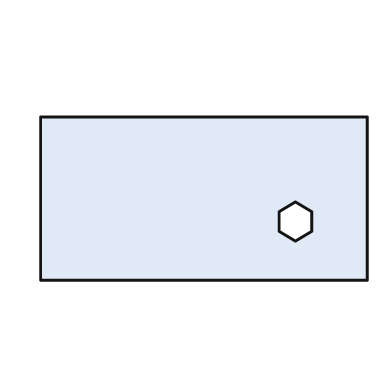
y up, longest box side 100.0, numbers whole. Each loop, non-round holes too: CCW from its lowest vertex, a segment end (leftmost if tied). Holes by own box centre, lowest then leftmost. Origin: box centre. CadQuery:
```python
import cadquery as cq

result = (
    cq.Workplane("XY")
    .moveTo(-50.0, -25.0)
    .lineTo(50.0, -25.0)
    .lineTo(50.0, 25.0)
    .lineTo(-50.0, 25.0)
    .close()
    .moveTo(28.0, -13.0)
    .lineTo(33.0, -10.0)
    .lineTo(33.0, -4.0)
    .lineTo(28.0, -1.0)
    .lineTo(23.0, -4.0)
    .lineTo(23.0, -10.0)
    .close()
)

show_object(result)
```